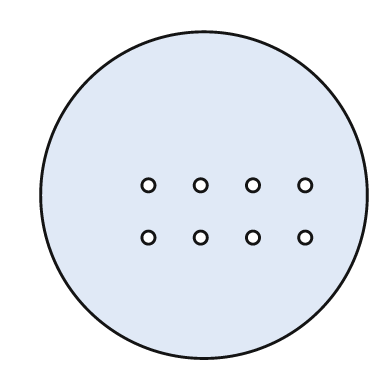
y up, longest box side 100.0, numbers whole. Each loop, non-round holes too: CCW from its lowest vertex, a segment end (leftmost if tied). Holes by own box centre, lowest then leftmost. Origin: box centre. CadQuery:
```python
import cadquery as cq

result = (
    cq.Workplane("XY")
    .moveTo(0.0, 0.0)
    .circle(50.0)
    .moveTo(-17.0, -13.0)
    .circle(2.0)
    .moveTo(-1.0, -13.0)
    .circle(2.0)
    .moveTo(15.0, -13.0)
    .circle(2.0)
    .moveTo(31.0, -13.0)
    .circle(2.0)
    .moveTo(-17.0, 3.0)
    .circle(2.0)
    .moveTo(-1.0, 3.0)
    .circle(2.0)
    .moveTo(15.0, 3.0)
    .circle(2.0)
    .moveTo(31.0, 3.0)
    .circle(2.0)
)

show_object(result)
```